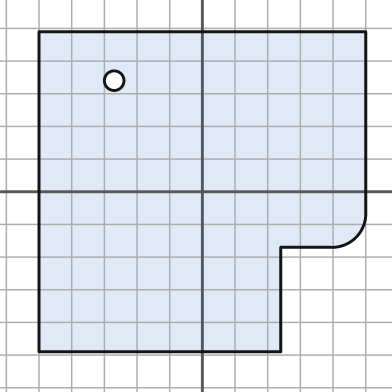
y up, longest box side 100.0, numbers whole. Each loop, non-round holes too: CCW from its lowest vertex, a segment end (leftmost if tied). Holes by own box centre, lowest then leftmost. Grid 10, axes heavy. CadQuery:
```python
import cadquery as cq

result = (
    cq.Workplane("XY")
    .moveTo(-50.0, -49.0)
    .lineTo(24.0, -49.0)
    .lineTo(24.0, -17.0)
    .lineTo(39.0, -17.0)
    .threePointArc((47.0, -14.0), (50.0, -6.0))
    .lineTo(50.0, 49.0)
    .lineTo(-50.0, 49.0)
    .close()
    .moveTo(-27.0, 34.0)
    .circle(3.0)
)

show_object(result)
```